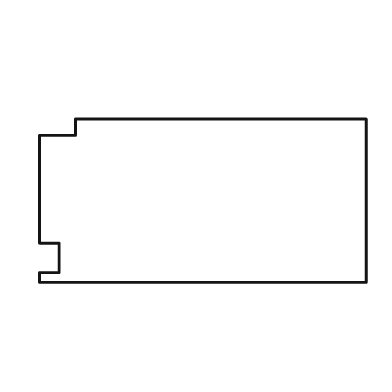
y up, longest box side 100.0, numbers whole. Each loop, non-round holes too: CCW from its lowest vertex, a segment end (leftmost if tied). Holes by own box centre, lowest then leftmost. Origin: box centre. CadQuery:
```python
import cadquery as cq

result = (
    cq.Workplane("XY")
    .moveTo(-50.0, -25.0)
    .lineTo(50.0, -25.0)
    .lineTo(50.0, 25.0)
    .lineTo(-39.0, 25.0)
    .lineTo(-39.0, 20.0)
    .lineTo(-50.0, 20.0)
    .lineTo(-50.0, -13.0)
    .lineTo(-44.0, -13.0)
    .lineTo(-44.0, -22.0)
    .lineTo(-50.0, -22.0)
    .close()
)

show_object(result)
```